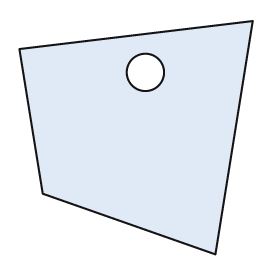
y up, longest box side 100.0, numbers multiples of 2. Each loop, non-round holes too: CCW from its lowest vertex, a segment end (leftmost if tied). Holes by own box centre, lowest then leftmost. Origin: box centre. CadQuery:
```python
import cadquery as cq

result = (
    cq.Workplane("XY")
    .moveTo(34.0, -50.0)
    .lineTo(50.0, 50.0)
    .lineTo(-50.0, 38.0)
    .lineTo(-40.0, -24.0)
    .close()
    .moveTo(4.0, 28.0)
    .circle(8.0)
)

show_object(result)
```